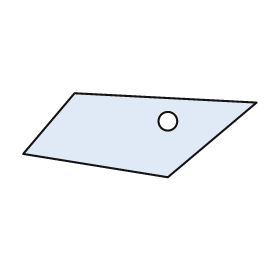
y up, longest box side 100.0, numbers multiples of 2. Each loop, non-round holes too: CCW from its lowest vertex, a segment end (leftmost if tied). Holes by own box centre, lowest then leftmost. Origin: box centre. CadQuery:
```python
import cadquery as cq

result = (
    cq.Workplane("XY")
    .moveTo(12.0, -18.0)
    .lineTo(50.0, 14.0)
    .lineTo(-28.0, 18.0)
    .lineTo(-50.0, -8.0)
    .close()
    .moveTo(12.0, 6.0)
    .circle(4.0)
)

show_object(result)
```